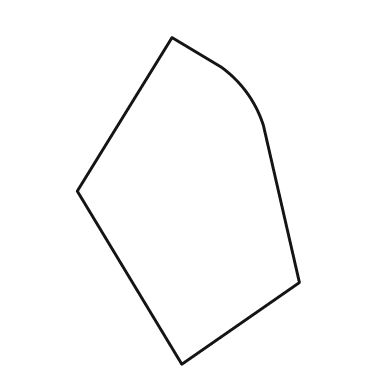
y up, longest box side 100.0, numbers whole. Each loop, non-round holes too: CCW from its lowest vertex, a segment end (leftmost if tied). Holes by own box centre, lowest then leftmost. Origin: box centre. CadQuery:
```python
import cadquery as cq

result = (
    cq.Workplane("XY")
    .moveTo(-2.0, -50.0)
    .lineTo(34.0, -25.0)
    .lineTo(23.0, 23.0)
    .threePointArc((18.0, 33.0), (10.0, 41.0))
    .lineTo(-5.0, 50.0)
    .lineTo(-34.0, 3.0)
    .close()
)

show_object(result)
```